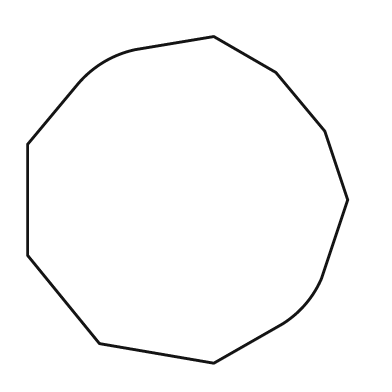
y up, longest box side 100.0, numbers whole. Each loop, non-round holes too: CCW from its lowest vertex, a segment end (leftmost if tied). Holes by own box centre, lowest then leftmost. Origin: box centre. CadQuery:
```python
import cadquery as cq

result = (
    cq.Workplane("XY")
    .moveTo(8.0, -50.0)
    .lineTo(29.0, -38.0)
    .threePointArc((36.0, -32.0), (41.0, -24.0))
    .lineTo(49.0, 0.0)
    .lineTo(42.0, 21.0)
    .lineTo(27.0, 39.0)
    .lineTo(8.0, 50.0)
    .lineTo(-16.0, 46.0)
    .threePointArc((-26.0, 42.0), (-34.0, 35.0))
    .lineTo(-49.0, 17.0)
    .lineTo(-49.0, -17.0)
    .lineTo(-27.0, -44.0)
    .close()
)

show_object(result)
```